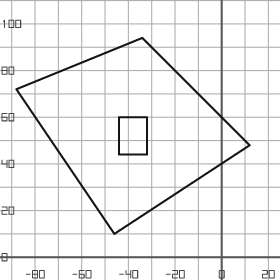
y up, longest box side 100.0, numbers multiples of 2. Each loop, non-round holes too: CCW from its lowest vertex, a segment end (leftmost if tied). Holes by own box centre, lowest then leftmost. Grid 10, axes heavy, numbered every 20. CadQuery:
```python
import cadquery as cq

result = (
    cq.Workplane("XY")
    .moveTo(-46.0, 10.0)
    .lineTo(12.0, 48.0)
    .lineTo(-34.0, 94.0)
    .lineTo(-88.0, 72.0)
    .close()
    .moveTo(-44.0, 44.0)
    .lineTo(-32.0, 44.0)
    .lineTo(-32.0, 60.0)
    .lineTo(-44.0, 60.0)
    .close()
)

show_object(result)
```